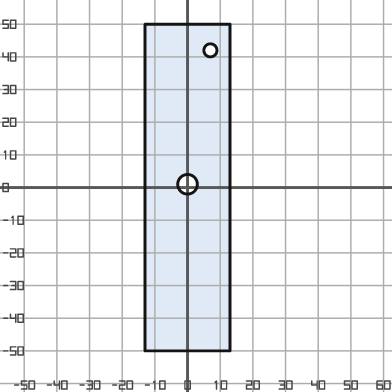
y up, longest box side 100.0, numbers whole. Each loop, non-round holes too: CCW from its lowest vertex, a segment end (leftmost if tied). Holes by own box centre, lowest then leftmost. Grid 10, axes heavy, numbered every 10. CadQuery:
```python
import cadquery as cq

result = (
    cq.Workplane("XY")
    .moveTo(-13.0, -50.0)
    .lineTo(13.0, -50.0)
    .lineTo(13.0, 50.0)
    .lineTo(-13.0, 50.0)
    .close()
    .moveTo(0.0, 1.0)
    .circle(3.0)
    .moveTo(7.0, 42.0)
    .circle(2.0)
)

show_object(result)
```